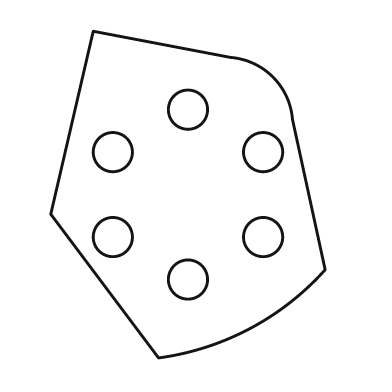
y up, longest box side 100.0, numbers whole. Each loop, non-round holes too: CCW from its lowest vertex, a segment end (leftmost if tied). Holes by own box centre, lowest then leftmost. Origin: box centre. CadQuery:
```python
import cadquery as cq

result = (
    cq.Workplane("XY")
    .moveTo(-9.0, -50.0)
    .threePointArc((19.0, -41.0), (42.0, -23.0))
    .lineTo(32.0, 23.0)
    .threePointArc((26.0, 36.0), (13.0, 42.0))
    .lineTo(-29.0, 50.0)
    .lineTo(-42.0, -6.0)
    .close()
    .moveTo(0.0, -26.0)
    .circle(6.0)
    .moveTo(-23.0, -13.0)
    .circle(6.0)
    .moveTo(23.0, -13.0)
    .circle(6.0)
    .moveTo(-23.0, 13.0)
    .circle(6.0)
    .moveTo(23.0, 13.0)
    .circle(6.0)
    .moveTo(0.0, 26.0)
    .circle(6.0)
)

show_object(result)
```